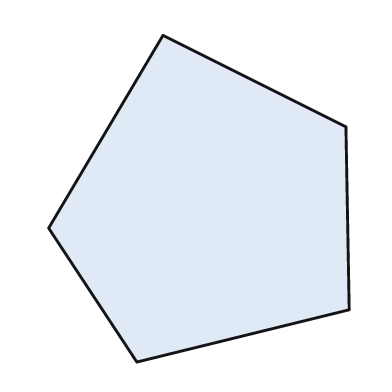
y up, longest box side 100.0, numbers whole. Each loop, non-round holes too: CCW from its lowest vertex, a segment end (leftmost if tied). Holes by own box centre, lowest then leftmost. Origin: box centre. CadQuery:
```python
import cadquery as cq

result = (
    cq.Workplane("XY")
    .moveTo(-19.0, -50.0)
    .lineTo(46.0, -34.0)
    .lineTo(45.0, 22.0)
    .lineTo(-11.0, 50.0)
    .lineTo(-46.0, -9.0)
    .close()
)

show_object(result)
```